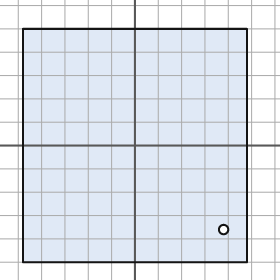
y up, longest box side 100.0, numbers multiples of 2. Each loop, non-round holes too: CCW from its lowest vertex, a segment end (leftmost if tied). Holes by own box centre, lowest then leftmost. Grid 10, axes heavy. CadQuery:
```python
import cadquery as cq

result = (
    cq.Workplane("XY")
    .moveTo(-48.0, -50.0)
    .lineTo(48.0, -50.0)
    .lineTo(48.0, 50.0)
    .lineTo(-48.0, 50.0)
    .close()
    .moveTo(38.0, -36.0)
    .circle(2.0)
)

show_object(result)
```